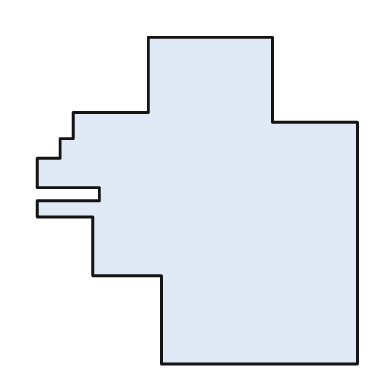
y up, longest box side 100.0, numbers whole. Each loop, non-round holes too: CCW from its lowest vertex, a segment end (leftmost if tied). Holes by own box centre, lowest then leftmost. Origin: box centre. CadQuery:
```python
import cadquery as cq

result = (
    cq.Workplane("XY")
    .moveTo(-11.0, -50.0)
    .lineTo(49.0, -50.0)
    .lineTo(49.0, 24.0)
    .lineTo(23.0, 24.0)
    .lineTo(23.0, 50.0)
    .lineTo(-15.0, 50.0)
    .lineTo(-15.0, 27.0)
    .lineTo(-38.0, 27.0)
    .lineTo(-38.0, 19.0)
    .lineTo(-42.0, 19.0)
    .lineTo(-42.0, 13.0)
    .lineTo(-49.0, 13.0)
    .lineTo(-49.0, 4.0)
    .lineTo(-30.0, 4.0)
    .lineTo(-30.0, 0.0)
    .lineTo(-49.0, 0.0)
    .lineTo(-49.0, -5.0)
    .lineTo(-32.0, -5.0)
    .lineTo(-32.0, -23.0)
    .lineTo(-11.0, -23.0)
    .close()
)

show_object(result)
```